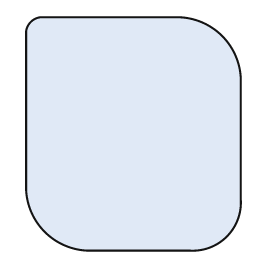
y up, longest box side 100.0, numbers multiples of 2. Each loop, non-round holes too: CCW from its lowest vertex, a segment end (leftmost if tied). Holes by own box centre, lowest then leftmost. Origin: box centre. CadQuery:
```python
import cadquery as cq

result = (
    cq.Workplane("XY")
    .moveTo(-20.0, -50.0)
    .lineTo(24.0, -50.0)
    .threePointArc((40.0, -44.0), (46.0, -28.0))
    .lineTo(46.0, 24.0)
    .threePointArc((38.0, 42.0), (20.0, 50.0))
    .lineTo(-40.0, 50.0)
    .threePointArc((-44.0, 48.0), (-46.0, 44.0))
    .lineTo(-46.0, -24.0)
    .threePointArc((-38.0, -42.0), (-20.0, -50.0))
    .close()
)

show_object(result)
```